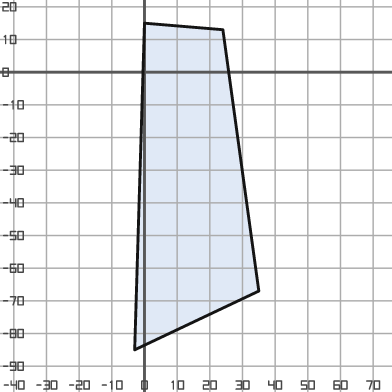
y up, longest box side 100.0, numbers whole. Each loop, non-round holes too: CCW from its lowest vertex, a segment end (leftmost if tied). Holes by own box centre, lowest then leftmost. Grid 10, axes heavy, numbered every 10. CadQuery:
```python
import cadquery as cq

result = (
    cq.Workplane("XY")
    .moveTo(-3.0, -85.0)
    .lineTo(35.0, -67.0)
    .lineTo(24.0, 13.0)
    .lineTo(0.0, 15.0)
    .close()
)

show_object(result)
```